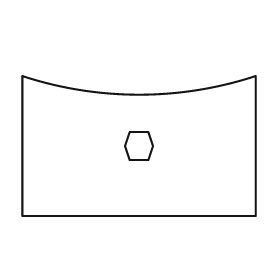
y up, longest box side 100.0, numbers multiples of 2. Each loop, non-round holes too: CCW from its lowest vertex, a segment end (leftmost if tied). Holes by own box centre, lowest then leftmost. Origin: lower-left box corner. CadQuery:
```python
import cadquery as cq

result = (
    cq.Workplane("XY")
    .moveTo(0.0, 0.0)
    .lineTo(100.0, 0.0)
    .lineTo(100.0, 60.0)
    .threePointArc((50.0, 52.0), (0.0, 60.0))
    .close()
    .moveTo(46.0, 24.0)
    .lineTo(54.0, 24.0)
    .lineTo(56.0, 30.0)
    .lineTo(54.0, 36.0)
    .lineTo(46.0, 36.0)
    .lineTo(44.0, 30.0)
    .close()
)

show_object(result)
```